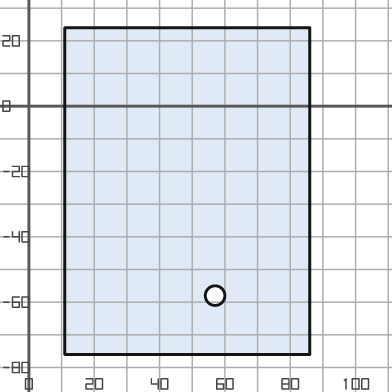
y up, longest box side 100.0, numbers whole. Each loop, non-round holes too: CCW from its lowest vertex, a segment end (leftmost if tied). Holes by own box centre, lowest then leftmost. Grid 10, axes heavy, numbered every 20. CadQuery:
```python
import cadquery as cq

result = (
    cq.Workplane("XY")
    .moveTo(11.0, -76.0)
    .lineTo(86.0, -76.0)
    .lineTo(86.0, 24.0)
    .lineTo(11.0, 24.0)
    .close()
    .moveTo(57.0, -58.0)
    .circle(3.0)
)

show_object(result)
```